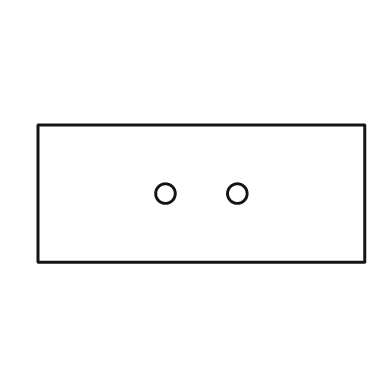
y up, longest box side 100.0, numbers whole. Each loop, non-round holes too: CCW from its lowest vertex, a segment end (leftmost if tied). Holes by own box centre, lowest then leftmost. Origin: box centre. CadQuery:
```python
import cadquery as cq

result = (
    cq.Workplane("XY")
    .moveTo(-50.0, -21.0)
    .lineTo(50.0, -21.0)
    .lineTo(50.0, 21.0)
    .lineTo(-50.0, 21.0)
    .close()
    .moveTo(-11.0, 0.0)
    .circle(3.0)
    .moveTo(11.0, 0.0)
    .circle(3.0)
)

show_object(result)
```